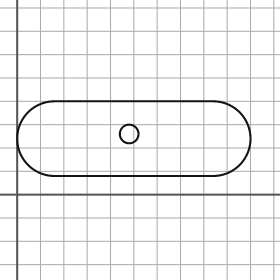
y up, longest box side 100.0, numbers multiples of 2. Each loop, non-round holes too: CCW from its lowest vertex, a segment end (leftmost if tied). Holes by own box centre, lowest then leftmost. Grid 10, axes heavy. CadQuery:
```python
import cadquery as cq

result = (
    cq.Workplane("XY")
    .moveTo(16.0, 8.0)
    .lineTo(84.0, 8.0)
    .threePointArc((100.0, 24.0), (84.0, 40.0))
    .lineTo(16.0, 40.0)
    .threePointArc((0.0, 24.0), (16.0, 8.0))
    .close()
    .moveTo(48.0, 26.0)
    .circle(4.0)
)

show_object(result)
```